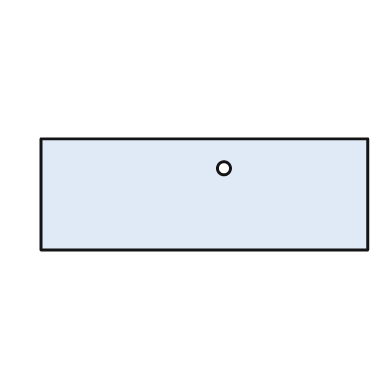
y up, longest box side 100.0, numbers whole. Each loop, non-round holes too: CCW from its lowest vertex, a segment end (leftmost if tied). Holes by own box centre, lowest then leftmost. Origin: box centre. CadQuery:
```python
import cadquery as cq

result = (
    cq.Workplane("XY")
    .moveTo(-50.0, -17.0)
    .lineTo(50.0, -17.0)
    .lineTo(50.0, 17.0)
    .lineTo(-50.0, 17.0)
    .close()
    .moveTo(6.0, 8.0)
    .circle(2.0)
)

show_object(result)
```